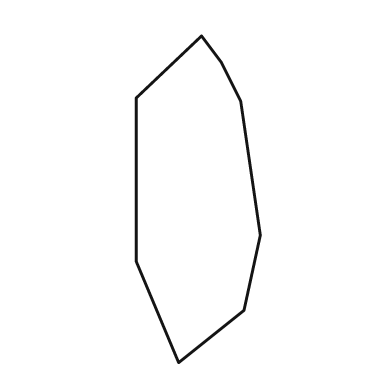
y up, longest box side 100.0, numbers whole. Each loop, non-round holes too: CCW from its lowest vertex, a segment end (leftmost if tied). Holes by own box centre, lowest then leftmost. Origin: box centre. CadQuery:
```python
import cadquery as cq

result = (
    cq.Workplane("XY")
    .moveTo(-6.0, -50.0)
    .lineTo(14.0, -34.0)
    .lineTo(19.0, -11.0)
    .lineTo(13.0, 30.0)
    .lineTo(7.0, 42.0)
    .lineTo(1.0, 50.0)
    .lineTo(-19.0, 31.0)
    .lineTo(-19.0, -19.0)
    .close()
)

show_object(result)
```